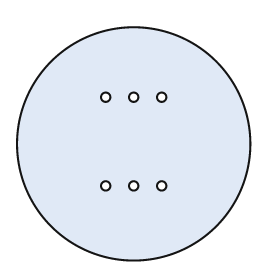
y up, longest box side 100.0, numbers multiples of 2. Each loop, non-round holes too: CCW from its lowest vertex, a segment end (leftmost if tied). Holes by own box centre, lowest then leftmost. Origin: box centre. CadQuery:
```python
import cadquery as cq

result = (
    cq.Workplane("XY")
    .moveTo(0.0, 0.0)
    .circle(50.0)
    .moveTo(-12.0, -18.0)
    .circle(2.0)
    .moveTo(0.0, -18.0)
    .circle(2.0)
    .moveTo(12.0, -18.0)
    .circle(2.0)
    .moveTo(-12.0, 20.0)
    .circle(2.0)
    .moveTo(0.0, 20.0)
    .circle(2.0)
    .moveTo(12.0, 20.0)
    .circle(2.0)
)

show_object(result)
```